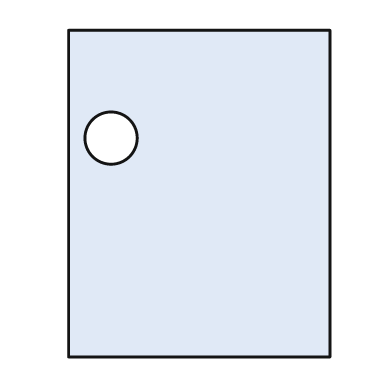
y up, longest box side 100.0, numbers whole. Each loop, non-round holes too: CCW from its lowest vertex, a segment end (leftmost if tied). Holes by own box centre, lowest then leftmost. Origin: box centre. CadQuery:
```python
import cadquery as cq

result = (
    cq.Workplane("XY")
    .moveTo(-40.0, -50.0)
    .lineTo(40.0, -50.0)
    .lineTo(40.0, 50.0)
    .lineTo(-40.0, 50.0)
    .close()
    .moveTo(-27.0, 17.0)
    .circle(8.0)
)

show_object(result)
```